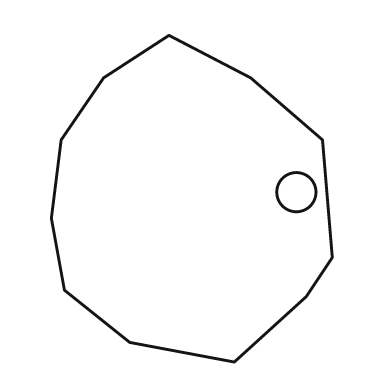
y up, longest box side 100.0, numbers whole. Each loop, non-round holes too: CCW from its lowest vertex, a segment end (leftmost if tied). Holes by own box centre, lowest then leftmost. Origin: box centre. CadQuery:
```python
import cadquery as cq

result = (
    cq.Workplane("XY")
    .moveTo(13.0, -50.0)
    .lineTo(35.0, -30.0)
    .lineTo(43.0, -18.0)
    .lineTo(40.0, 18.0)
    .lineTo(18.0, 37.0)
    .lineTo(-7.0, 50.0)
    .lineTo(-27.0, 37.0)
    .lineTo(-40.0, 18.0)
    .lineTo(-43.0, -6.0)
    .lineTo(-39.0, -28.0)
    .lineTo(-19.0, -44.0)
    .close()
    .moveTo(32.0, 2.0)
    .circle(6.0)
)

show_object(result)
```